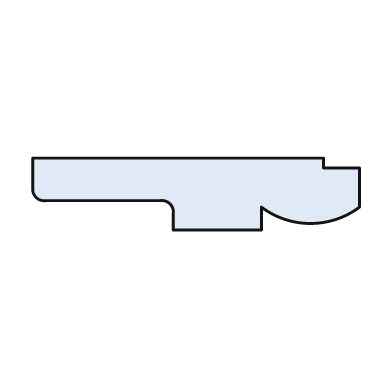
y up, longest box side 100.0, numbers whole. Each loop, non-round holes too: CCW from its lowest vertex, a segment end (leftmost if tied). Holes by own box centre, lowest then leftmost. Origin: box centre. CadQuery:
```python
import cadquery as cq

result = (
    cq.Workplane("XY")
    .moveTo(-7.0, -11.0)
    .lineTo(20.0, -11.0)
    .lineTo(20.0, -4.0)
    .threePointArc((35.0, -9.0), (50.0, -4.0))
    .lineTo(50.0, 8.0)
    .lineTo(39.0, 8.0)
    .lineTo(39.0, 11.0)
    .lineTo(-50.0, 11.0)
    .lineTo(-50.0, 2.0)
    .threePointArc((-49.0, -1.0), (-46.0, -2.0))
    .lineTo(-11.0, -2.0)
    .threePointArc((-8.0, -3.0), (-7.0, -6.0))
    .close()
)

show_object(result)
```